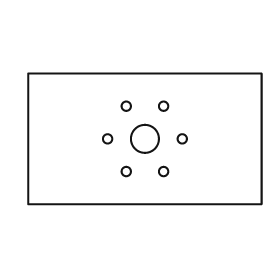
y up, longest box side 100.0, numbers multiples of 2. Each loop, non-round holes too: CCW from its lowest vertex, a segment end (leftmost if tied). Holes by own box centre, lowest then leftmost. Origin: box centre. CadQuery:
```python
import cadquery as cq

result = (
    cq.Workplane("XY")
    .moveTo(-50.0, -28.0)
    .lineTo(50.0, -28.0)
    .lineTo(50.0, 28.0)
    .lineTo(-50.0, 28.0)
    .close()
    .moveTo(-8.0, -14.0)
    .circle(2.0)
    .moveTo(8.0, -14.0)
    .circle(2.0)
    .moveTo(-16.0, 0.0)
    .circle(2.0)
    .moveTo(0.0, 0.0)
    .circle(6.0)
    .moveTo(16.0, 0.0)
    .circle(2.0)
    .moveTo(-8.0, 14.0)
    .circle(2.0)
    .moveTo(8.0, 14.0)
    .circle(2.0)
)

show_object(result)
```